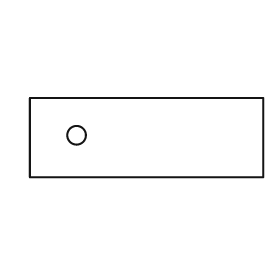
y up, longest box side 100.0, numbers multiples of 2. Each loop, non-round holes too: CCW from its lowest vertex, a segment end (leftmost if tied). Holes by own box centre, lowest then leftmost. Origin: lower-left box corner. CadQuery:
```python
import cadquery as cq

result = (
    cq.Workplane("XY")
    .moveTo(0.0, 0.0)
    .lineTo(100.0, 0.0)
    .lineTo(100.0, 34.0)
    .lineTo(0.0, 34.0)
    .close()
    .moveTo(20.0, 18.0)
    .circle(4.0)
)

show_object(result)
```